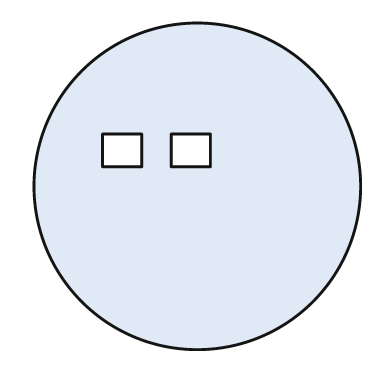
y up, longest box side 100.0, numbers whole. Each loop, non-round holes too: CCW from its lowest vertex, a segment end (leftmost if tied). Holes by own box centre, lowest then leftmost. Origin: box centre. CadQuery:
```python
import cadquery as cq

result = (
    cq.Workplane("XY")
    .moveTo(0.0, 0.0)
    .circle(50.0)
    .moveTo(-29.0, 6.0)
    .lineTo(-17.0, 6.0)
    .lineTo(-17.0, 16.0)
    .lineTo(-29.0, 16.0)
    .close()
    .moveTo(-8.0, 6.0)
    .lineTo(4.0, 6.0)
    .lineTo(4.0, 16.0)
    .lineTo(-8.0, 16.0)
    .close()
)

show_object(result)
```